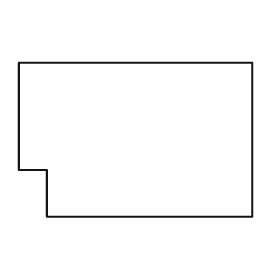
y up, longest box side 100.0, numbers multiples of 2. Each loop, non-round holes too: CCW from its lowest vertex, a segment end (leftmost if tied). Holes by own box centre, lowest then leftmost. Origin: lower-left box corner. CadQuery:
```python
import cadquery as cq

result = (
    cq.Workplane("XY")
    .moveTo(12.0, 0.0)
    .lineTo(100.0, 0.0)
    .lineTo(100.0, 66.0)
    .lineTo(0.0, 66.0)
    .lineTo(0.0, 20.0)
    .lineTo(12.0, 20.0)
    .close()
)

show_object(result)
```